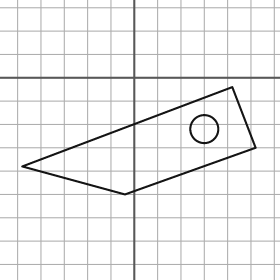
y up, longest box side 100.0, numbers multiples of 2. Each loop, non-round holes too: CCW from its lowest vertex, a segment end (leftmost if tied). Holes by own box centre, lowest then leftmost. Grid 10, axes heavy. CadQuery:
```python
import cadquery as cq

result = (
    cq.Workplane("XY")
    .moveTo(-4.0, -50.0)
    .lineTo(52.0, -30.0)
    .lineTo(42.0, -4.0)
    .lineTo(-48.0, -38.0)
    .close()
    .moveTo(30.0, -22.0)
    .circle(6.0)
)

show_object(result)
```